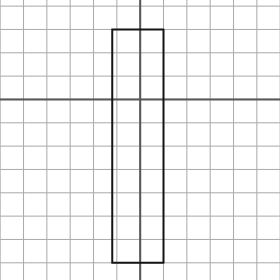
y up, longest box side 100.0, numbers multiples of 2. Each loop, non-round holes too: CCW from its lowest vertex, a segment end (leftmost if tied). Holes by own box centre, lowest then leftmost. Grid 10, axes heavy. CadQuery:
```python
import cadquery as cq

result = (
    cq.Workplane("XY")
    .moveTo(-12.0, -70.0)
    .lineTo(10.0, -70.0)
    .lineTo(10.0, 30.0)
    .lineTo(-12.0, 30.0)
    .close()
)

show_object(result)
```